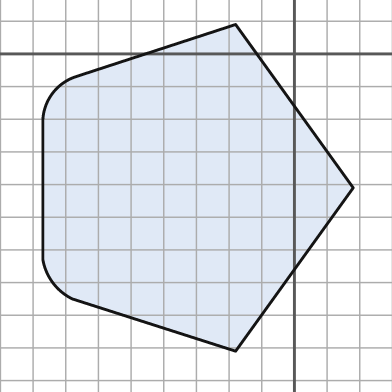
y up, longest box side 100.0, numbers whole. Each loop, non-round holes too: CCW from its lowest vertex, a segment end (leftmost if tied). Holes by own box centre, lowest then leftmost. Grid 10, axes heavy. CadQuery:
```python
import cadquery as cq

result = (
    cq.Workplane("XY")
    .moveTo(-18.0, -91.0)
    .lineTo(18.0, -41.0)
    .lineTo(-18.0, 9.0)
    .lineTo(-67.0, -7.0)
    .threePointArc((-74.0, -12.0), (-77.0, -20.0))
    .lineTo(-77.0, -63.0)
    .threePointArc((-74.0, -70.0), (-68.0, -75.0))
    .close()
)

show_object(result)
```